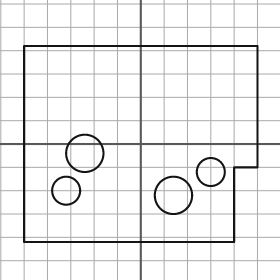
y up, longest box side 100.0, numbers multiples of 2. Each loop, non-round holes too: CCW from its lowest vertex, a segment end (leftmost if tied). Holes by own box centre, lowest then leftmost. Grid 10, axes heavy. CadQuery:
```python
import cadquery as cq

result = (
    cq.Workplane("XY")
    .moveTo(-50.0, -42.0)
    .lineTo(40.0, -42.0)
    .lineTo(40.0, -10.0)
    .lineTo(50.0, -10.0)
    .lineTo(50.0, 42.0)
    .lineTo(-50.0, 42.0)
    .close()
    .moveTo(14.0, -22.0)
    .circle(8.0)
    .moveTo(-32.0, -20.0)
    .circle(6.0)
    .moveTo(30.0, -12.0)
    .circle(6.0)
    .moveTo(-24.0, -4.0)
    .circle(8.0)
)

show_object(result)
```